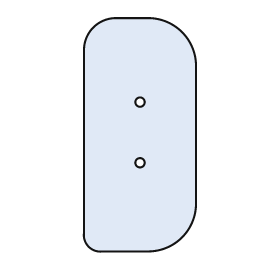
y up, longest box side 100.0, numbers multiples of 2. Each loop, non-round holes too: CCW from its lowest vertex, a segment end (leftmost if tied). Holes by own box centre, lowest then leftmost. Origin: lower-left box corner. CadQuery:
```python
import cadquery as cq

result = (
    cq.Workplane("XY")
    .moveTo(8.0, 0.0)
    .lineTo(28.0, 0.0)
    .threePointArc((42.0, 6.0), (48.0, 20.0))
    .lineTo(48.0, 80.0)
    .threePointArc((42.0, 94.0), (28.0, 100.0))
    .lineTo(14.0, 100.0)
    .threePointArc((4.0, 96.0), (0.0, 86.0))
    .lineTo(0.0, 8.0)
    .threePointArc((2.0, 2.0), (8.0, 0.0))
    .close()
    .moveTo(24.0, 38.0)
    .circle(2.0)
    .moveTo(24.0, 64.0)
    .circle(2.0)
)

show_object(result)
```